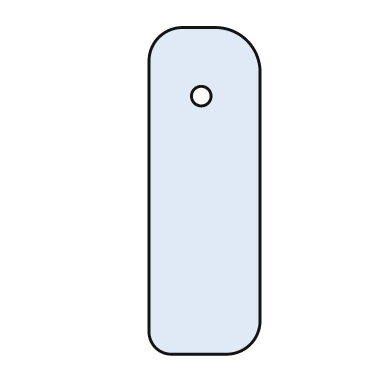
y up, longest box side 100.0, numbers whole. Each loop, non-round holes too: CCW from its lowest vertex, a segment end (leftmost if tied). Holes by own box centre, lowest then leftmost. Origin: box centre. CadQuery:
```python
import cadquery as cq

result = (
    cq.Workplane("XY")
    .moveTo(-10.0, -50.0)
    .lineTo(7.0, -50.0)
    .threePointArc((14.0, -47.0), (17.0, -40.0))
    .lineTo(17.0, 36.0)
    .threePointArc((13.0, 46.0), (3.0, 50.0))
    .lineTo(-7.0, 50.0)
    .threePointArc((-14.0, 47.0), (-17.0, 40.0))
    .lineTo(-17.0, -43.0)
    .threePointArc((-15.0, -48.0), (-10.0, -50.0))
    .close()
    .moveTo(-1.0, 29.0)
    .circle(3.0)
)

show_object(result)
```